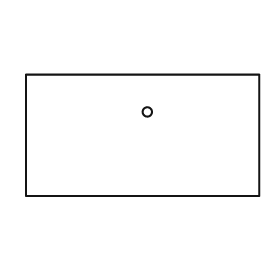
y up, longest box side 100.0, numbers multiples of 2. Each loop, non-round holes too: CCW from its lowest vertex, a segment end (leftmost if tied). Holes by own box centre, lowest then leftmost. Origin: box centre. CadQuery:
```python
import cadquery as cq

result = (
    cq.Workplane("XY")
    .moveTo(-50.0, -26.0)
    .lineTo(50.0, -26.0)
    .lineTo(50.0, 26.0)
    .lineTo(-50.0, 26.0)
    .close()
    .moveTo(2.0, 10.0)
    .circle(2.0)
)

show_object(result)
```